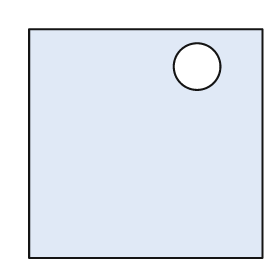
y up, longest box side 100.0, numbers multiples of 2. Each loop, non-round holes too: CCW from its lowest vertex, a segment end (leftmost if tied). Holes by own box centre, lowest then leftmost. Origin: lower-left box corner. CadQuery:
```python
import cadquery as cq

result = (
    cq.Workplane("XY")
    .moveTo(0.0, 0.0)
    .lineTo(100.0, 0.0)
    .lineTo(100.0, 98.0)
    .lineTo(0.0, 98.0)
    .close()
    .moveTo(72.0, 82.0)
    .circle(10.0)
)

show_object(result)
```